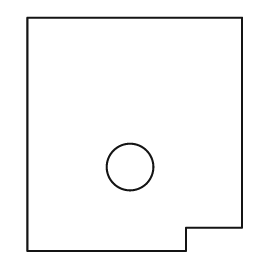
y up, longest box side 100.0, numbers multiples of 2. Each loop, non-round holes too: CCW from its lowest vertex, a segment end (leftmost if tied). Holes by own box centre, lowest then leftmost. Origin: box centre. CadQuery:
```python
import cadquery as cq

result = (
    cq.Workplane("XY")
    .moveTo(-46.0, -50.0)
    .lineTo(22.0, -50.0)
    .lineTo(22.0, -40.0)
    .lineTo(46.0, -40.0)
    .lineTo(46.0, 50.0)
    .lineTo(-46.0, 50.0)
    .close()
    .moveTo(-2.0, -14.0)
    .circle(10.0)
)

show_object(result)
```